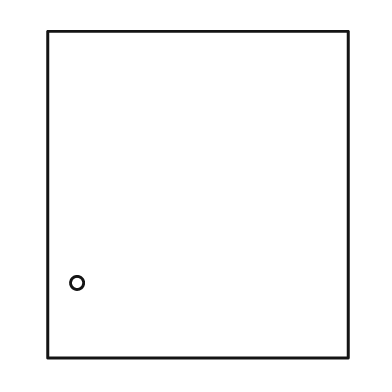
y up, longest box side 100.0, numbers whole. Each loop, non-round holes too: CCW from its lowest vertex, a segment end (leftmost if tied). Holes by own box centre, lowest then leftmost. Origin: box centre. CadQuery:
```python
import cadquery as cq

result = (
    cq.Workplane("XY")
    .moveTo(-46.0, -50.0)
    .lineTo(46.0, -50.0)
    .lineTo(46.0, 50.0)
    .lineTo(-46.0, 50.0)
    .close()
    .moveTo(-37.0, -27.0)
    .circle(2.0)
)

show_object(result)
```